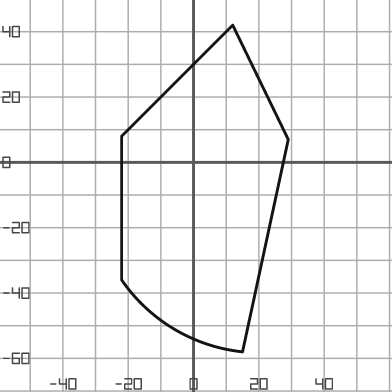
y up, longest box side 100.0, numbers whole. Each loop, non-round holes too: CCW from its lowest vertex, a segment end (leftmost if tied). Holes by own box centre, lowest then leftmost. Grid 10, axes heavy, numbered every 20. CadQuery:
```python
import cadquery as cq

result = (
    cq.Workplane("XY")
    .moveTo(15.0, -58.0)
    .lineTo(29.0, 7.0)
    .lineTo(12.0, 42.0)
    .lineTo(-22.0, 8.0)
    .lineTo(-22.0, -36.0)
    .threePointArc((-6.0, -51.0), (15.0, -58.0))
    .close()
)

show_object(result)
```